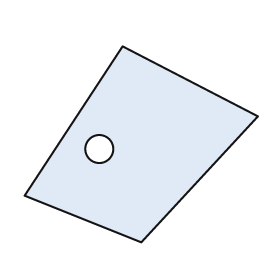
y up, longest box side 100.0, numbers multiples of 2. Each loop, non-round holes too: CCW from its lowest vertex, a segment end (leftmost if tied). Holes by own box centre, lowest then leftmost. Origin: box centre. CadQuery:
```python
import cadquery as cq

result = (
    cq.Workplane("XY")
    .moveTo(0.0, -42.0)
    .lineTo(50.0, 12.0)
    .lineTo(-8.0, 42.0)
    .lineTo(-50.0, -22.0)
    .close()
    .moveTo(-18.0, -2.0)
    .circle(6.0)
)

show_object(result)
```